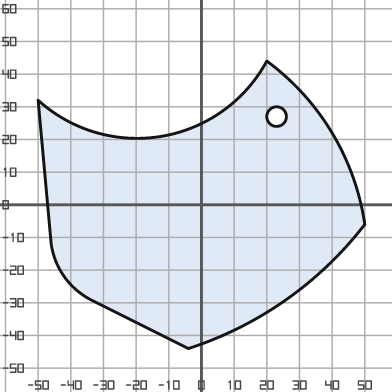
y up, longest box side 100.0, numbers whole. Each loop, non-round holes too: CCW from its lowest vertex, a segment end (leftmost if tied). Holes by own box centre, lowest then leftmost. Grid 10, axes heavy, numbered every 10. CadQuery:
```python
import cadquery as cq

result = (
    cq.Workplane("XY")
    .moveTo(-4.0, -44.0)
    .threePointArc((26.0, -29.0), (50.0, -6.0))
    .threePointArc((40.0, 22.0), (20.0, 44.0))
    .threePointArc((-12.0, 21.0), (-50.0, 32.0))
    .lineTo(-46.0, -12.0)
    .threePointArc((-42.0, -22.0), (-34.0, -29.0))
    .close()
    .moveTo(23.0, 27.0)
    .circle(3.0)
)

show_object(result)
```